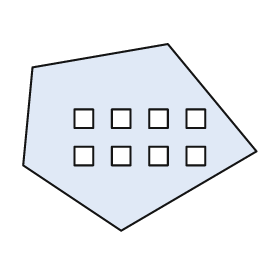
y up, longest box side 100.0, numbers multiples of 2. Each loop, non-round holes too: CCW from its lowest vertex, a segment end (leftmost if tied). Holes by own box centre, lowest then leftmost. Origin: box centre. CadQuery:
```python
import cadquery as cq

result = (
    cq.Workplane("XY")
    .moveTo(-8.0, -40.0)
    .lineTo(50.0, -6.0)
    .lineTo(12.0, 40.0)
    .lineTo(-46.0, 30.0)
    .lineTo(-50.0, -12.0)
    .close()
    .moveTo(-28.0, -12.0)
    .lineTo(-20.0, -12.0)
    .lineTo(-20.0, -4.0)
    .lineTo(-28.0, -4.0)
    .close()
    .moveTo(-12.0, -12.0)
    .lineTo(-4.0, -12.0)
    .lineTo(-4.0, -4.0)
    .lineTo(-12.0, -4.0)
    .close()
    .moveTo(4.0, -12.0)
    .lineTo(12.0, -12.0)
    .lineTo(12.0, -4.0)
    .lineTo(4.0, -4.0)
    .close()
    .moveTo(20.0, -12.0)
    .lineTo(28.0, -12.0)
    .lineTo(28.0, -4.0)
    .lineTo(20.0, -4.0)
    .close()
    .moveTo(-28.0, 4.0)
    .lineTo(-20.0, 4.0)
    .lineTo(-20.0, 12.0)
    .lineTo(-28.0, 12.0)
    .close()
    .moveTo(-12.0, 4.0)
    .lineTo(-4.0, 4.0)
    .lineTo(-4.0, 12.0)
    .lineTo(-12.0, 12.0)
    .close()
    .moveTo(4.0, 4.0)
    .lineTo(12.0, 4.0)
    .lineTo(12.0, 12.0)
    .lineTo(4.0, 12.0)
    .close()
    .moveTo(20.0, 4.0)
    .lineTo(28.0, 4.0)
    .lineTo(28.0, 12.0)
    .lineTo(20.0, 12.0)
    .close()
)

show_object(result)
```